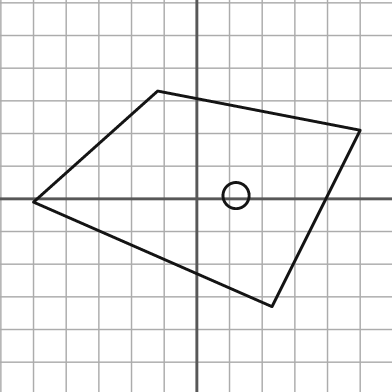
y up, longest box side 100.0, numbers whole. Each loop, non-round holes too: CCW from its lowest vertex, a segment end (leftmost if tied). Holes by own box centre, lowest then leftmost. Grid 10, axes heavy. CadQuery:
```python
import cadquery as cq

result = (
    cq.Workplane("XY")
    .moveTo(23.0, -33.0)
    .lineTo(50.0, 21.0)
    .lineTo(-12.0, 33.0)
    .lineTo(-50.0, -1.0)
    .close()
    .moveTo(12.0, 1.0)
    .circle(4.0)
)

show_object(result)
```